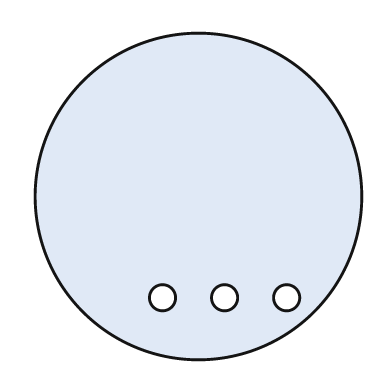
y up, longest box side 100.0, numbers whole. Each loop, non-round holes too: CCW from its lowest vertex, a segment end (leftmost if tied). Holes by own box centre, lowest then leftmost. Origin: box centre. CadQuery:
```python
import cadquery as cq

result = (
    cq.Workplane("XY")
    .moveTo(0.0, 0.0)
    .circle(50.0)
    .moveTo(-11.0, -31.0)
    .circle(4.0)
    .moveTo(8.0, -31.0)
    .circle(4.0)
    .moveTo(27.0, -31.0)
    .circle(4.0)
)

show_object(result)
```